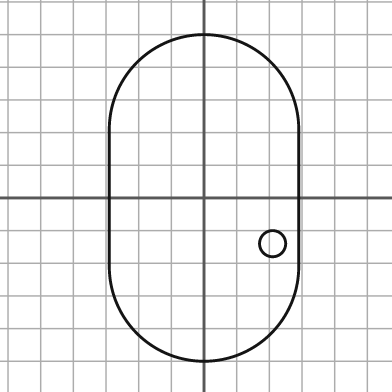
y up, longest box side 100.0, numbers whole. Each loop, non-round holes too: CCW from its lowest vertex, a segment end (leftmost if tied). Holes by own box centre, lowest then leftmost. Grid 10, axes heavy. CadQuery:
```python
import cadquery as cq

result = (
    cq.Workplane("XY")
    .moveTo(-29.0, -21.0)
    .threePointArc((0.0, -50.0), (29.0, -21.0))
    .lineTo(29.0, 21.0)
    .threePointArc((0.0, 50.0), (-29.0, 21.0))
    .close()
    .moveTo(21.0, -14.0)
    .circle(4.0)
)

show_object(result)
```